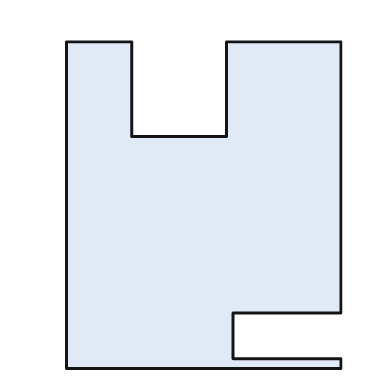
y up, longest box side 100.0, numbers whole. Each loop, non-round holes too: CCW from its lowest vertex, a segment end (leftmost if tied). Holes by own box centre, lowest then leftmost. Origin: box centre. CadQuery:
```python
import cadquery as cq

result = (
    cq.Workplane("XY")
    .moveTo(-42.0, -50.0)
    .lineTo(42.0, -50.0)
    .lineTo(42.0, -47.0)
    .lineTo(9.0, -47.0)
    .lineTo(9.0, -33.0)
    .lineTo(42.0, -33.0)
    .lineTo(42.0, 50.0)
    .lineTo(7.0, 50.0)
    .lineTo(7.0, 21.0)
    .lineTo(-22.0, 21.0)
    .lineTo(-22.0, 50.0)
    .lineTo(-42.0, 50.0)
    .close()
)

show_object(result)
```